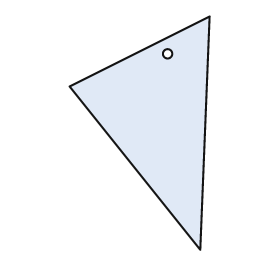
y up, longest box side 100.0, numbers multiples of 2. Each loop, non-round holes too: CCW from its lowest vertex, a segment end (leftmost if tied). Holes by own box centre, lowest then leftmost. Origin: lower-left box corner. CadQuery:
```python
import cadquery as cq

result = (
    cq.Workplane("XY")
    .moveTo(56.0, 0.0)
    .lineTo(60.0, 100.0)
    .lineTo(0.0, 70.0)
    .close()
    .moveTo(42.0, 84.0)
    .circle(2.0)
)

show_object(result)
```